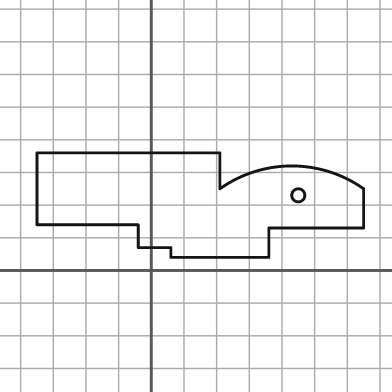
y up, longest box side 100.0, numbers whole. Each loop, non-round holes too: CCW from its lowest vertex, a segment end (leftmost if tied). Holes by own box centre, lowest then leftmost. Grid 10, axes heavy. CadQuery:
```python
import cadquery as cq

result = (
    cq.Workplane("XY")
    .moveTo(6.0, 4.0)
    .lineTo(36.0, 4.0)
    .lineTo(36.0, 13.0)
    .lineTo(65.0, 13.0)
    .lineTo(65.0, 25.0)
    .threePointArc((43.0, 32.0), (21.0, 25.0))
    .lineTo(21.0, 36.0)
    .lineTo(-35.0, 36.0)
    .lineTo(-35.0, 14.0)
    .lineTo(-4.0, 14.0)
    .lineTo(-4.0, 7.0)
    .lineTo(6.0, 7.0)
    .close()
    .moveTo(45.0, 23.0)
    .circle(2.0)
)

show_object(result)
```